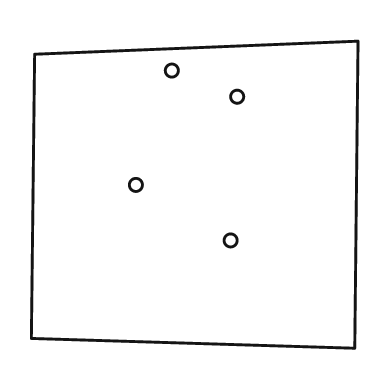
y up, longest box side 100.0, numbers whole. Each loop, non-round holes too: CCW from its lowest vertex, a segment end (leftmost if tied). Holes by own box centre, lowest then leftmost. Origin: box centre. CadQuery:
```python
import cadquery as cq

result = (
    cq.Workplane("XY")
    .moveTo(49.0, -47.0)
    .lineTo(50.0, 47.0)
    .lineTo(-49.0, 43.0)
    .lineTo(-50.0, -44.0)
    .close()
    .moveTo(11.0, -14.0)
    .circle(2.0)
    .moveTo(-18.0, 3.0)
    .circle(2.0)
    .moveTo(13.0, 30.0)
    .circle(2.0)
    .moveTo(-7.0, 38.0)
    .circle(2.0)
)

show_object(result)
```